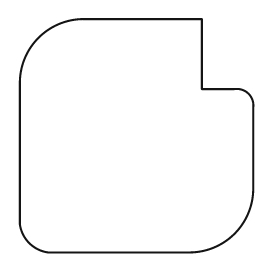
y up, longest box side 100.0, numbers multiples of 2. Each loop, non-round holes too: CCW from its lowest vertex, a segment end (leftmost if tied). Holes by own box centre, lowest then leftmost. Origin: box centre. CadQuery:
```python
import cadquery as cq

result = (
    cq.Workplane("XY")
    .moveTo(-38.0, -50.0)
    .lineTo(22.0, -50.0)
    .threePointArc((42.0, -42.0), (50.0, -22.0))
    .lineTo(50.0, 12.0)
    .threePointArc((48.0, 18.0), (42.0, 20.0))
    .lineTo(28.0, 20.0)
    .lineTo(28.0, 50.0)
    .lineTo(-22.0, 50.0)
    .threePointArc((-42.0, 42.0), (-50.0, 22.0))
    .lineTo(-50.0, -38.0)
    .threePointArc((-46.0, -46.0), (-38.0, -50.0))
    .close()
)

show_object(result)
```